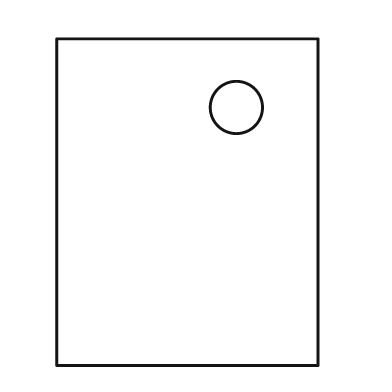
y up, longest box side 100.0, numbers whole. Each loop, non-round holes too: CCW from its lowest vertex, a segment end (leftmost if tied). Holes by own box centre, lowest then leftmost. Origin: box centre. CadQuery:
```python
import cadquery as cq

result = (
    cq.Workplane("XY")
    .moveTo(-40.0, -50.0)
    .lineTo(40.0, -50.0)
    .lineTo(40.0, 50.0)
    .lineTo(-40.0, 50.0)
    .close()
    .moveTo(15.0, 29.0)
    .circle(8.0)
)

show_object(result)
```